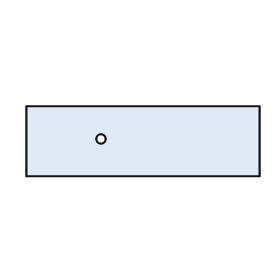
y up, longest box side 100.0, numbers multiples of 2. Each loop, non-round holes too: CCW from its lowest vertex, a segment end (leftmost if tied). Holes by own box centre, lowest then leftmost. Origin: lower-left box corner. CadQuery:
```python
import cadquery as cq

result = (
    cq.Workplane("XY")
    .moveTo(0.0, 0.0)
    .lineTo(100.0, 0.0)
    .lineTo(100.0, 30.0)
    .lineTo(0.0, 30.0)
    .close()
    .moveTo(32.0, 16.0)
    .circle(2.0)
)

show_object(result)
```